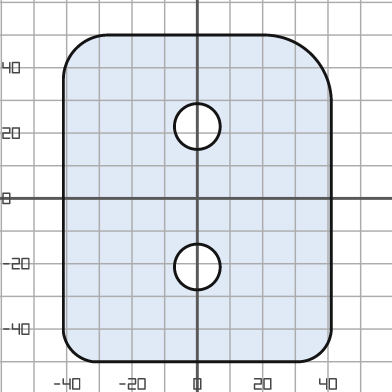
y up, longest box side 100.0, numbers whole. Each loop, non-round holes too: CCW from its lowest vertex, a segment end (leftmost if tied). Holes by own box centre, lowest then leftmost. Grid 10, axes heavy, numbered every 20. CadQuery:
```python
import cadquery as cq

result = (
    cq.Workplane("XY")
    .moveTo(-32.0, -50.0)
    .lineTo(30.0, -50.0)
    .threePointArc((38.0, -47.0), (41.0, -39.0))
    .lineTo(41.0, 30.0)
    .threePointArc((35.0, 44.0), (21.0, 50.0))
    .lineTo(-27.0, 50.0)
    .threePointArc((-37.0, 46.0), (-41.0, 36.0))
    .lineTo(-41.0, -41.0)
    .threePointArc((-38.0, -47.0), (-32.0, -50.0))
    .close()
    .moveTo(0.0, -21.0)
    .circle(7.0)
    .moveTo(0.0, 22.0)
    .circle(7.0)
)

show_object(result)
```